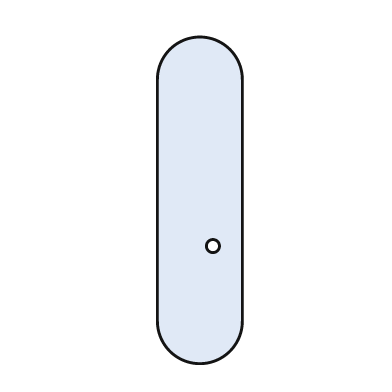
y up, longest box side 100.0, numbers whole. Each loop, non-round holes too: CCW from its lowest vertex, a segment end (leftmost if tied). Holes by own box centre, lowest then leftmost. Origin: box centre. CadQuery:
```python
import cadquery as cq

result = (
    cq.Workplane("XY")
    .moveTo(-13.0, -37.0)
    .threePointArc((0.0, -50.0), (13.0, -37.0))
    .lineTo(13.0, 37.0)
    .threePointArc((0.0, 50.0), (-13.0, 37.0))
    .close()
    .moveTo(4.0, -14.0)
    .circle(2.0)
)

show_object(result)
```